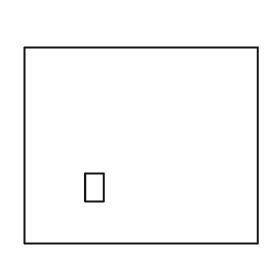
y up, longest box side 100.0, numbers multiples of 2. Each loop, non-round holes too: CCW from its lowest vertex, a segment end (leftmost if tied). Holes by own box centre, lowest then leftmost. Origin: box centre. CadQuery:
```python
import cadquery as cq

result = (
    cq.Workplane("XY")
    .moveTo(-50.0, -42.0)
    .lineTo(50.0, -42.0)
    .lineTo(50.0, 42.0)
    .lineTo(-50.0, 42.0)
    .close()
    .moveTo(-24.0, -24.0)
    .lineTo(-16.0, -24.0)
    .lineTo(-16.0, -12.0)
    .lineTo(-24.0, -12.0)
    .close()
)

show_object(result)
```